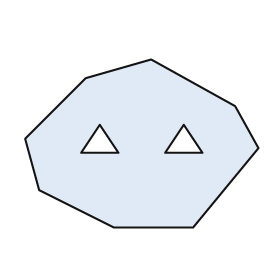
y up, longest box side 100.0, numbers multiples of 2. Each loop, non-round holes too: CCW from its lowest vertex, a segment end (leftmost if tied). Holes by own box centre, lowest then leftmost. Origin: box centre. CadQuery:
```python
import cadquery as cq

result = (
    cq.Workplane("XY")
    .moveTo(-12.0, -36.0)
    .lineTo(22.0, -36.0)
    .lineTo(50.0, -2.0)
    .lineTo(40.0, 16.0)
    .lineTo(4.0, 36.0)
    .lineTo(-24.0, 28.0)
    .lineTo(-50.0, 2.0)
    .lineTo(-44.0, -20.0)
    .close()
    .moveTo(-26.0, -4.0)
    .lineTo(-10.0, -4.0)
    .lineTo(-18.0, 8.0)
    .close()
    .moveTo(10.0, -4.0)
    .lineTo(26.0, -4.0)
    .lineTo(18.0, 8.0)
    .close()
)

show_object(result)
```